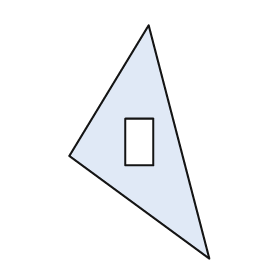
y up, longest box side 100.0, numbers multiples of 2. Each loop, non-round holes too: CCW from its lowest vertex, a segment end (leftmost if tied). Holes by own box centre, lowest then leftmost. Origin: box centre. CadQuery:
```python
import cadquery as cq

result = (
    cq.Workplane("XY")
    .moveTo(30.0, -50.0)
    .lineTo(4.0, 50.0)
    .lineTo(-30.0, -6.0)
    .close()
    .moveTo(-6.0, -10.0)
    .lineTo(6.0, -10.0)
    .lineTo(6.0, 10.0)
    .lineTo(-6.0, 10.0)
    .close()
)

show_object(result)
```